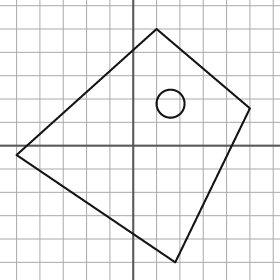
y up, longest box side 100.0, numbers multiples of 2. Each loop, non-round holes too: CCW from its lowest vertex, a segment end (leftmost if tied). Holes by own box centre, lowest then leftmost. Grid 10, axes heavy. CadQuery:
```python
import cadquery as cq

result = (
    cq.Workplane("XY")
    .moveTo(18.0, -50.0)
    .lineTo(50.0, 16.0)
    .lineTo(10.0, 50.0)
    .lineTo(-50.0, -4.0)
    .close()
    .moveTo(16.0, 18.0)
    .circle(6.0)
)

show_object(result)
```